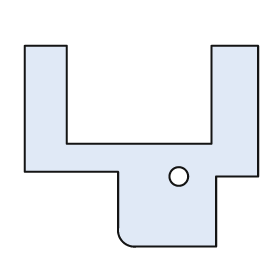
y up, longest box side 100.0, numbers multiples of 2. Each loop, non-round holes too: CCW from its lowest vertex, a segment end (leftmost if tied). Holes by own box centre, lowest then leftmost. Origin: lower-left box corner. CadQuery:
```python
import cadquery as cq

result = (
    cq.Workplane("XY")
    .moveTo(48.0, 0.0)
    .lineTo(82.0, 0.0)
    .lineTo(82.0, 30.0)
    .lineTo(100.0, 30.0)
    .lineTo(100.0, 86.0)
    .lineTo(80.0, 86.0)
    .lineTo(80.0, 44.0)
    .lineTo(18.0, 44.0)
    .lineTo(18.0, 86.0)
    .lineTo(0.0, 86.0)
    .lineTo(0.0, 32.0)
    .lineTo(40.0, 32.0)
    .lineTo(40.0, 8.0)
    .threePointArc((42.0, 2.0), (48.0, 0.0))
    .close()
    .moveTo(66.0, 30.0)
    .circle(4.0)
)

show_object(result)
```